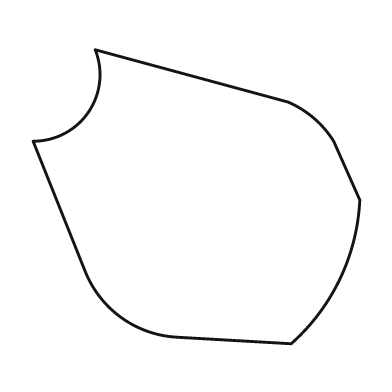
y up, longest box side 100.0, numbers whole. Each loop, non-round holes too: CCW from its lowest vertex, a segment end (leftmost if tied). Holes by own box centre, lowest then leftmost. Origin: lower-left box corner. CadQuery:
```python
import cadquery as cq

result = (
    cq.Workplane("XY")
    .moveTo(79.0, 0.0)
    .threePointArc((94.0, 20.0), (100.0, 44.0))
    .lineTo(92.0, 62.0)
    .threePointArc((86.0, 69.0), (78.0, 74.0))
    .lineTo(19.0, 90.0)
    .threePointArc((17.0, 71.0), (0.0, 62.0))
    .lineTo(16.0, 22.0)
    .threePointArc((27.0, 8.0), (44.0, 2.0))
    .close()
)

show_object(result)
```